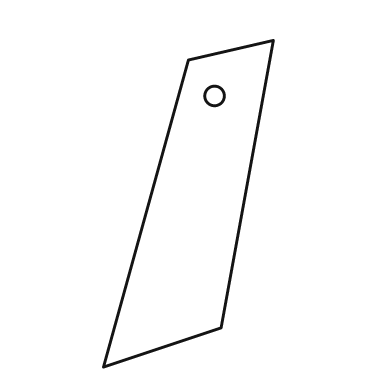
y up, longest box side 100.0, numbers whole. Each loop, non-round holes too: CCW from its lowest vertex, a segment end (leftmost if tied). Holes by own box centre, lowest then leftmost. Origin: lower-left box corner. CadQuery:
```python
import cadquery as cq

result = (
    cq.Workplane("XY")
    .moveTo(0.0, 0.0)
    .lineTo(36.0, 12.0)
    .lineTo(52.0, 100.0)
    .lineTo(26.0, 94.0)
    .close()
    .moveTo(34.0, 83.0)
    .circle(3.0)
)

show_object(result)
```